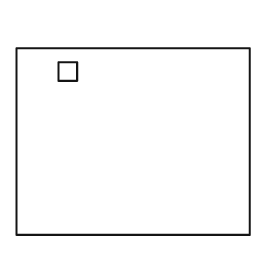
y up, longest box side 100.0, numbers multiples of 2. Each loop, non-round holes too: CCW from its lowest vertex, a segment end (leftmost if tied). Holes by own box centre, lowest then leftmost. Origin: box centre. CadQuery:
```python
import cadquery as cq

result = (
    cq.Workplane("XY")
    .moveTo(-50.0, -40.0)
    .lineTo(50.0, -40.0)
    .lineTo(50.0, 40.0)
    .lineTo(-50.0, 40.0)
    .close()
    .moveTo(-32.0, 26.0)
    .lineTo(-24.0, 26.0)
    .lineTo(-24.0, 34.0)
    .lineTo(-32.0, 34.0)
    .close()
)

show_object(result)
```